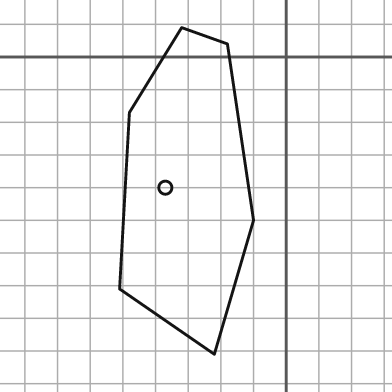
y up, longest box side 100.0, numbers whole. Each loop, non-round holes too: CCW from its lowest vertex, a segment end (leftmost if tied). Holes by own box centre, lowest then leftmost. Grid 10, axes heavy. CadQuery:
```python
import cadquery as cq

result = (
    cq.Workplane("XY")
    .moveTo(-22.0, -91.0)
    .lineTo(-10.0, -50.0)
    .lineTo(-18.0, 4.0)
    .lineTo(-32.0, 9.0)
    .lineTo(-48.0, -17.0)
    .lineTo(-51.0, -71.0)
    .close()
    .moveTo(-37.0, -40.0)
    .circle(2.0)
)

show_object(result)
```